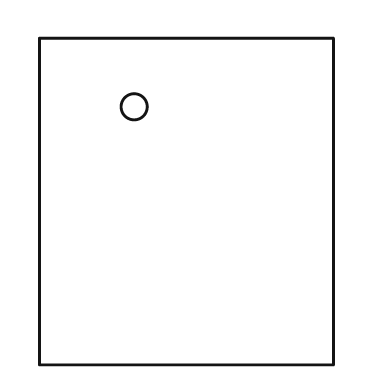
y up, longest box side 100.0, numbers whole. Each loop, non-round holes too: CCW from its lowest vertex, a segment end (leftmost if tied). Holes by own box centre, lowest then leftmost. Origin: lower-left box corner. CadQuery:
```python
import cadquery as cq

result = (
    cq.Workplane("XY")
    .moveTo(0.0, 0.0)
    .lineTo(90.0, 0.0)
    .lineTo(90.0, 100.0)
    .lineTo(0.0, 100.0)
    .close()
    .moveTo(29.0, 79.0)
    .circle(4.0)
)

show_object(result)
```